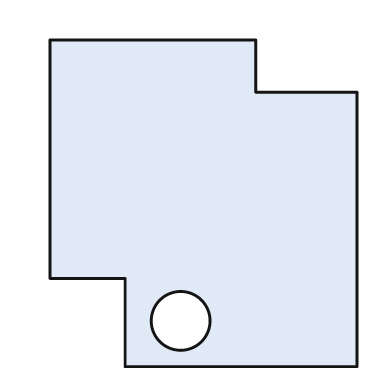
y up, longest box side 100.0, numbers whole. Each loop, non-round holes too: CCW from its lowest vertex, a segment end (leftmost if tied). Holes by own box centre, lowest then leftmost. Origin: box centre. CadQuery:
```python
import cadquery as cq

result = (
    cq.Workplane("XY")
    .moveTo(-24.0, -50.0)
    .lineTo(47.0, -50.0)
    .lineTo(47.0, 34.0)
    .lineTo(16.0, 34.0)
    .lineTo(16.0, 50.0)
    .lineTo(-47.0, 50.0)
    .lineTo(-47.0, -23.0)
    .lineTo(-24.0, -23.0)
    .close()
    .moveTo(-7.0, -36.0)
    .circle(9.0)
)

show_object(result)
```